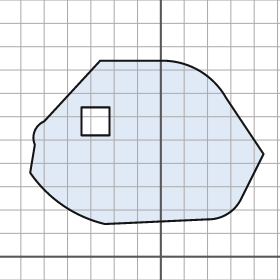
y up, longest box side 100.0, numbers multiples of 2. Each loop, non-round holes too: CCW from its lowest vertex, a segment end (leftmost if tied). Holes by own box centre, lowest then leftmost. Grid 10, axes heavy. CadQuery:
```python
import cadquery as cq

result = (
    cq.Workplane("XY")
    .moveTo(-24.0, 14.0)
    .lineTo(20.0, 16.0)
    .threePointArc((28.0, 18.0), (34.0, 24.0))
    .lineTo(44.0, 44.0)
    .lineTo(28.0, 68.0)
    .threePointArc((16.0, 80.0), (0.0, 84.0))
    .lineTo(-26.0, 84.0)
    .lineTo(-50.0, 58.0)
    .threePointArc((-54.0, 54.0), (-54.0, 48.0))
    .lineTo(-56.0, 36.0)
    .threePointArc((-42.0, 22.0), (-24.0, 14.0))
    .close()
    .moveTo(-34.0, 52.0)
    .lineTo(-22.0, 52.0)
    .lineTo(-22.0, 64.0)
    .lineTo(-34.0, 64.0)
    .close()
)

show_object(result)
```